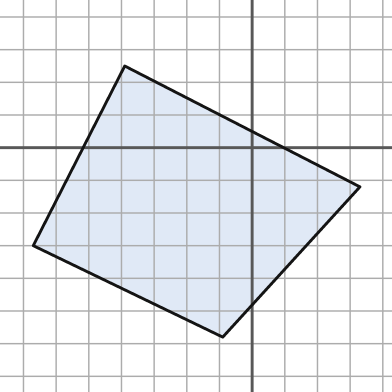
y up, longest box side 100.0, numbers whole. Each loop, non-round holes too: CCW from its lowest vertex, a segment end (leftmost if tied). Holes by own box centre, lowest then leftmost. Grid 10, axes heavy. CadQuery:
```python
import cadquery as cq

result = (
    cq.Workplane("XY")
    .moveTo(-9.0, -58.0)
    .lineTo(33.0, -12.0)
    .lineTo(-39.0, 25.0)
    .lineTo(-67.0, -30.0)
    .close()
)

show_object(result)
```